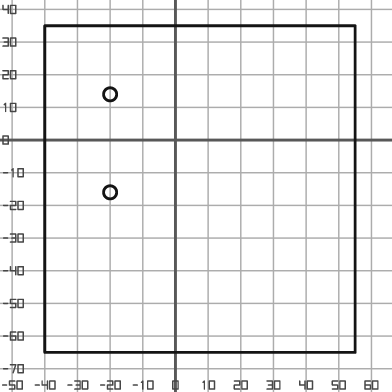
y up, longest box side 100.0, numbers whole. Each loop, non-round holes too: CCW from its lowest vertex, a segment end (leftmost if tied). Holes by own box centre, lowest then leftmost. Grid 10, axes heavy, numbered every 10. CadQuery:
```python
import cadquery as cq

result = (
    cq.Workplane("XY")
    .moveTo(-40.0, -65.0)
    .lineTo(55.0, -65.0)
    .lineTo(55.0, 35.0)
    .lineTo(-40.0, 35.0)
    .close()
    .moveTo(-20.0, -16.0)
    .circle(2.0)
    .moveTo(-20.0, 14.0)
    .circle(2.0)
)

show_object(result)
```